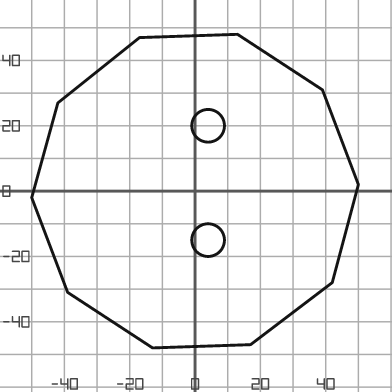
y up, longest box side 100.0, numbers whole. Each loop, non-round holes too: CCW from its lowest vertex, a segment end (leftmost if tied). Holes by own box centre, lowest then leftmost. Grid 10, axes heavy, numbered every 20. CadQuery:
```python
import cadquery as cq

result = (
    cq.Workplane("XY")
    .moveTo(-13.0, -48.0)
    .lineTo(17.0, -47.0)
    .lineTo(42.0, -28.0)
    .lineTo(50.0, 2.0)
    .lineTo(39.0, 31.0)
    .lineTo(13.0, 48.0)
    .lineTo(-17.0, 47.0)
    .lineTo(-42.0, 27.0)
    .lineTo(-50.0, -2.0)
    .lineTo(-39.0, -31.0)
    .close()
    .moveTo(4.0, -15.0)
    .circle(5.0)
    .moveTo(4.0, 20.0)
    .circle(5.0)
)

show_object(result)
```